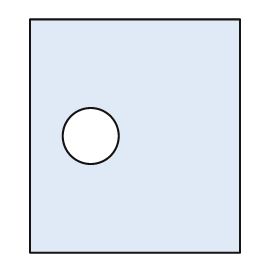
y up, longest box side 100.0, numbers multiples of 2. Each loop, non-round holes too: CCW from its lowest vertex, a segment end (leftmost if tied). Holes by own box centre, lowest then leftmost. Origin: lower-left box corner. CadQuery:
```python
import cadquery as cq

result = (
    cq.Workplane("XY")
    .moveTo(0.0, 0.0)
    .lineTo(90.0, 0.0)
    .lineTo(90.0, 100.0)
    .lineTo(0.0, 100.0)
    .close()
    .moveTo(26.0, 50.0)
    .circle(12.0)
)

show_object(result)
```